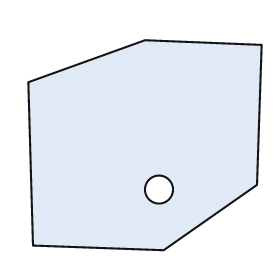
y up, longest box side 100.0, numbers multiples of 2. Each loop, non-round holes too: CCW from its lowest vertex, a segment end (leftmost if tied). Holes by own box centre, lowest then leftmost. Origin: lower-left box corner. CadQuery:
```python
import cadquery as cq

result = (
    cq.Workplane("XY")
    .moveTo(58.0, 0.0)
    .lineTo(98.0, 28.0)
    .lineTo(100.0, 88.0)
    .lineTo(50.0, 90.0)
    .lineTo(0.0, 72.0)
    .lineTo(2.0, 2.0)
    .close()
    .moveTo(56.0, 26.0)
    .circle(6.0)
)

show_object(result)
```